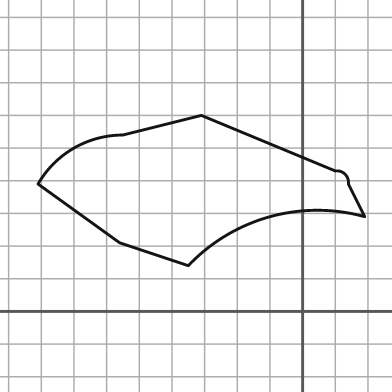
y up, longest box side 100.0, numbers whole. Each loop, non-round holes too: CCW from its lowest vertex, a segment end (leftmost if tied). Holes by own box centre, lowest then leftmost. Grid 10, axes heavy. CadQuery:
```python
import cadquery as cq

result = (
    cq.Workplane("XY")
    .moveTo(-35.0, 14.0)
    .threePointArc((-10.0, 29.0), (19.0, 29.0))
    .lineTo(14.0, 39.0)
    .threePointArc((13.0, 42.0), (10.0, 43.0))
    .lineTo(-31.0, 60.0)
    .lineTo(-55.0, 54.0)
    .threePointArc((-70.0, 50.0), (-81.0, 39.0))
    .lineTo(-56.0, 21.0)
    .close()
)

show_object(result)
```